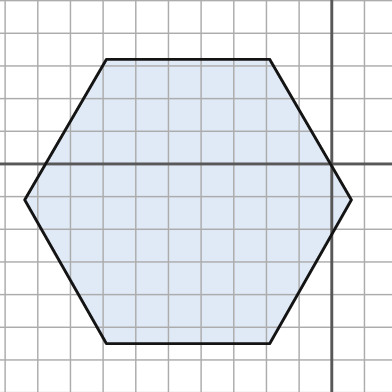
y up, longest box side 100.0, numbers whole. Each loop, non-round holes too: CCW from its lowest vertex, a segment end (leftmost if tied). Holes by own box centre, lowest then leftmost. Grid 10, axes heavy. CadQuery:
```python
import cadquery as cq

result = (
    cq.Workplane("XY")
    .moveTo(-69.0, -55.0)
    .lineTo(-19.0, -55.0)
    .lineTo(6.0, -11.0)
    .lineTo(-19.0, 32.0)
    .lineTo(-69.0, 32.0)
    .lineTo(-94.0, -11.0)
    .close()
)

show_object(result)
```